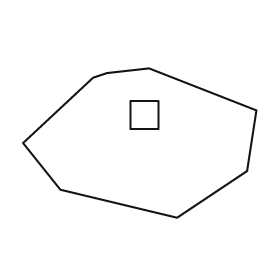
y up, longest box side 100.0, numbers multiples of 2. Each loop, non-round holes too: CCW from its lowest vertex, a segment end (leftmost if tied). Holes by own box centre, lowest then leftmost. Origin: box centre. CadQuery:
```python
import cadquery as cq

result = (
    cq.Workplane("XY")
    .moveTo(16.0, -32.0)
    .lineTo(46.0, -12.0)
    .lineTo(50.0, 14.0)
    .lineTo(4.0, 32.0)
    .lineTo(-14.0, 30.0)
    .lineTo(-20.0, 28.0)
    .lineTo(-50.0, 0.0)
    .lineTo(-34.0, -20.0)
    .close()
    .moveTo(-4.0, 6.0)
    .lineTo(8.0, 6.0)
    .lineTo(8.0, 18.0)
    .lineTo(-4.0, 18.0)
    .close()
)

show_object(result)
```